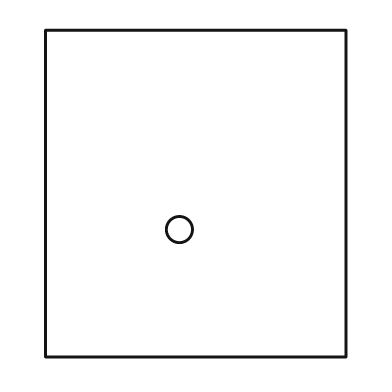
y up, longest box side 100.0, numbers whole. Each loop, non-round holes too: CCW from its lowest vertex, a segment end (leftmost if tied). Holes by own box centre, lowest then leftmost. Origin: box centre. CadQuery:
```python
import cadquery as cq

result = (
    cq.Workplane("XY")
    .moveTo(-46.0, -50.0)
    .lineTo(46.0, -50.0)
    .lineTo(46.0, 50.0)
    .lineTo(-46.0, 50.0)
    .close()
    .moveTo(-5.0, -11.0)
    .circle(4.0)
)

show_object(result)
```